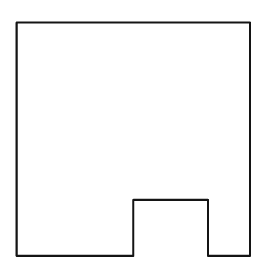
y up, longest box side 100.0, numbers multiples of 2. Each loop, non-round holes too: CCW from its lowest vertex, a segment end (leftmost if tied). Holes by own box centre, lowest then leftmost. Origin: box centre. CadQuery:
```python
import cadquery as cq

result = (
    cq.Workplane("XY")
    .moveTo(-50.0, -50.0)
    .lineTo(0.0, -50.0)
    .lineTo(0.0, -26.0)
    .lineTo(32.0, -26.0)
    .lineTo(32.0, -50.0)
    .lineTo(50.0, -50.0)
    .lineTo(50.0, 50.0)
    .lineTo(-50.0, 50.0)
    .close()
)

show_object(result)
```